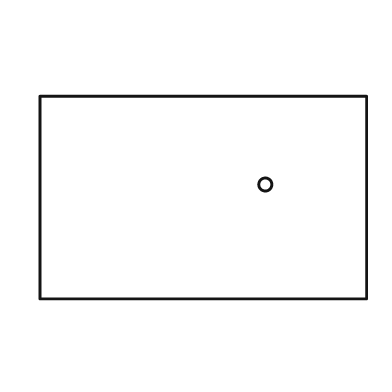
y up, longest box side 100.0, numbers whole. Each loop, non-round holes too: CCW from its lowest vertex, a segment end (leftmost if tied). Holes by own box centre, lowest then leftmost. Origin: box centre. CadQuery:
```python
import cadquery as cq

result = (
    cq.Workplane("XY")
    .moveTo(-50.0, -31.0)
    .lineTo(50.0, -31.0)
    .lineTo(50.0, 31.0)
    .lineTo(-50.0, 31.0)
    .close()
    .moveTo(19.0, 4.0)
    .circle(2.0)
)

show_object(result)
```